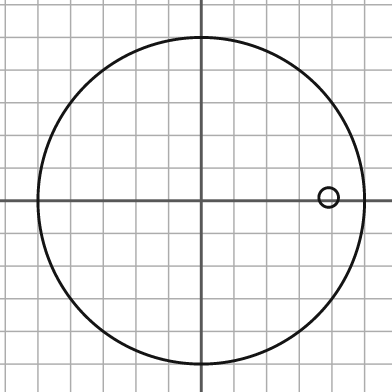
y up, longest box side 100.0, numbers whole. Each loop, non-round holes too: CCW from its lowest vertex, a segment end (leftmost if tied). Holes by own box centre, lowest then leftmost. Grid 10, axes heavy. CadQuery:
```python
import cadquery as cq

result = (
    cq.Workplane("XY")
    .moveTo(0.0, 0.0)
    .circle(50.0)
    .moveTo(39.0, 1.0)
    .circle(3.0)
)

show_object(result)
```